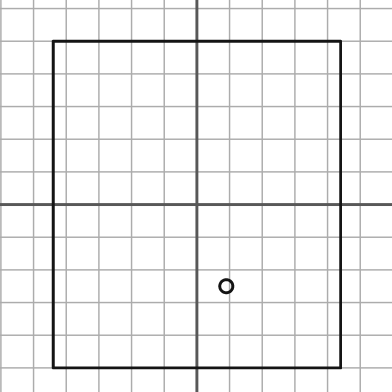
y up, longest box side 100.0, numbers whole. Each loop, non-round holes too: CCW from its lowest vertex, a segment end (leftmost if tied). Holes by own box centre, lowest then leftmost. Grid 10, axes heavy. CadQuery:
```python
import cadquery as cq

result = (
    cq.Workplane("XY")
    .moveTo(-44.0, -50.0)
    .lineTo(44.0, -50.0)
    .lineTo(44.0, 50.0)
    .lineTo(-44.0, 50.0)
    .close()
    .moveTo(9.0, -25.0)
    .circle(2.0)
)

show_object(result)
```